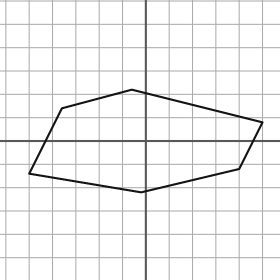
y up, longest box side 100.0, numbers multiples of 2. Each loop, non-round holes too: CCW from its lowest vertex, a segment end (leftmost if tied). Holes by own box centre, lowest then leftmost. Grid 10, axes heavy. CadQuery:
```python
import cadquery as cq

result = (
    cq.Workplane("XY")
    .moveTo(-2.0, -22.0)
    .lineTo(40.0, -12.0)
    .lineTo(50.0, 8.0)
    .lineTo(-6.0, 22.0)
    .lineTo(-36.0, 14.0)
    .lineTo(-50.0, -14.0)
    .close()
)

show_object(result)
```